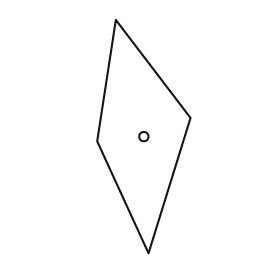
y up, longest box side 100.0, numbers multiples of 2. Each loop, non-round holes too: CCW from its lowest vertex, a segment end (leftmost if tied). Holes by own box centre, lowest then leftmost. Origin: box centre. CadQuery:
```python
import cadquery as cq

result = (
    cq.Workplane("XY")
    .moveTo(2.0, -50.0)
    .lineTo(20.0, 8.0)
    .lineTo(-12.0, 50.0)
    .lineTo(-20.0, -2.0)
    .close()
    .moveTo(0.0, 0.0)
    .circle(2.0)
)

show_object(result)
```